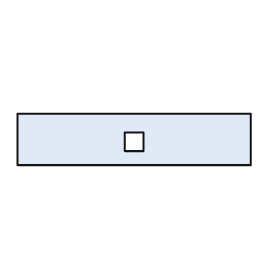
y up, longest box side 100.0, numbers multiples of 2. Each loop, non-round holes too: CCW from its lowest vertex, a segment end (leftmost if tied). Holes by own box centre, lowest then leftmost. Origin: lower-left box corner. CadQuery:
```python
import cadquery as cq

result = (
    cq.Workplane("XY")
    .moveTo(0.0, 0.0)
    .lineTo(100.0, 0.0)
    .lineTo(100.0, 22.0)
    .lineTo(0.0, 22.0)
    .close()
    .moveTo(46.0, 6.0)
    .lineTo(54.0, 6.0)
    .lineTo(54.0, 14.0)
    .lineTo(46.0, 14.0)
    .close()
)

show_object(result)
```